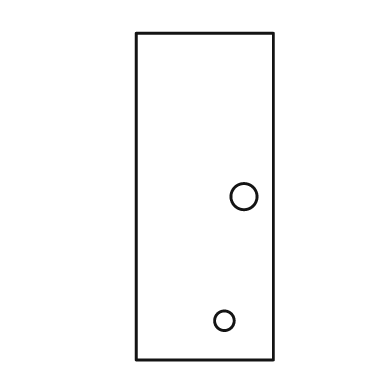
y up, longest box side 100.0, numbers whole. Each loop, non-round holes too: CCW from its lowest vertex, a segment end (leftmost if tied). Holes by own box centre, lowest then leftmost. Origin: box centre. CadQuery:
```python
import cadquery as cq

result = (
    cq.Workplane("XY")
    .moveTo(-21.0, -50.0)
    .lineTo(21.0, -50.0)
    .lineTo(21.0, 50.0)
    .lineTo(-21.0, 50.0)
    .close()
    .moveTo(6.0, -38.0)
    .circle(3.0)
    .moveTo(12.0, 0.0)
    .circle(4.0)
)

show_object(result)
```